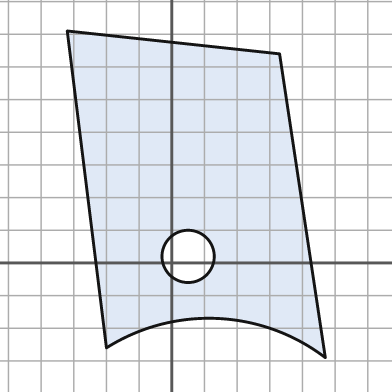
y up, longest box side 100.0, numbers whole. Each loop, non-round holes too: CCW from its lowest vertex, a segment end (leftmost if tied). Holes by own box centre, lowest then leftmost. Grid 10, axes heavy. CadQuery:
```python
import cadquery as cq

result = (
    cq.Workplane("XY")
    .moveTo(47.0, -29.0)
    .lineTo(33.0, 64.0)
    .lineTo(-32.0, 71.0)
    .lineTo(-20.0, -26.0)
    .threePointArc((14.0, -17.0), (47.0, -29.0))
    .close()
    .moveTo(5.0, 2.0)
    .circle(8.0)
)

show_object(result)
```